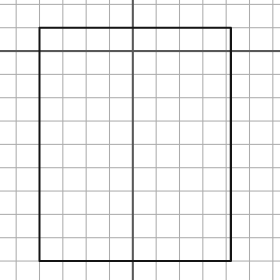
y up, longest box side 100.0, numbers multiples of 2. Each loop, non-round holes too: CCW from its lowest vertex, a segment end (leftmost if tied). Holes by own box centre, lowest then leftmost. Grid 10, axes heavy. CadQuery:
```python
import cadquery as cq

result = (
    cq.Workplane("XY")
    .moveTo(-40.0, -90.0)
    .lineTo(42.0, -90.0)
    .lineTo(42.0, 10.0)
    .lineTo(-40.0, 10.0)
    .close()
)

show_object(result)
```